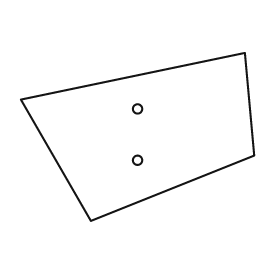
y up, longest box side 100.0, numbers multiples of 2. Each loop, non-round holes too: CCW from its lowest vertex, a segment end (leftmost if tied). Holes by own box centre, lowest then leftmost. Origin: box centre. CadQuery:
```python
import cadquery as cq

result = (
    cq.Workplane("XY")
    .moveTo(-20.0, -36.0)
    .lineTo(50.0, -8.0)
    .lineTo(46.0, 36.0)
    .lineTo(-50.0, 16.0)
    .close()
    .moveTo(0.0, -10.0)
    .circle(2.0)
    .moveTo(0.0, 12.0)
    .circle(2.0)
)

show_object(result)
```